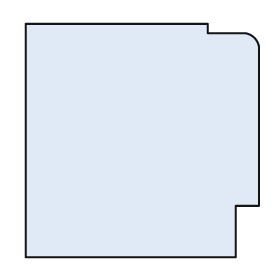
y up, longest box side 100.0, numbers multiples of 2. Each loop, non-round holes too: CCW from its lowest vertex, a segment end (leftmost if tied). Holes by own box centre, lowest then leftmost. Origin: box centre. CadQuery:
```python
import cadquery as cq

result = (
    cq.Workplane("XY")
    .moveTo(-50.0, -50.0)
    .lineTo(40.0, -50.0)
    .lineTo(40.0, -28.0)
    .lineTo(50.0, -28.0)
    .lineTo(50.0, 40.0)
    .threePointArc((48.0, 44.0), (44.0, 46.0))
    .lineTo(28.0, 46.0)
    .lineTo(28.0, 50.0)
    .lineTo(-50.0, 50.0)
    .close()
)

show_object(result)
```